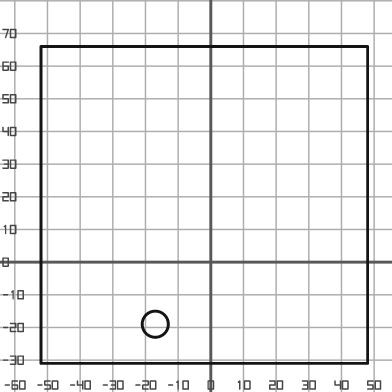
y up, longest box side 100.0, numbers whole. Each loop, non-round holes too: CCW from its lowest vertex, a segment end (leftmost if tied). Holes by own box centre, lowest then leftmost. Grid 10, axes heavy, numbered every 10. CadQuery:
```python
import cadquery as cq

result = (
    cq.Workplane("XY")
    .moveTo(-52.0, -31.0)
    .lineTo(48.0, -31.0)
    .lineTo(48.0, 66.0)
    .lineTo(-52.0, 66.0)
    .close()
    .moveTo(-17.0, -19.0)
    .circle(4.0)
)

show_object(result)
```